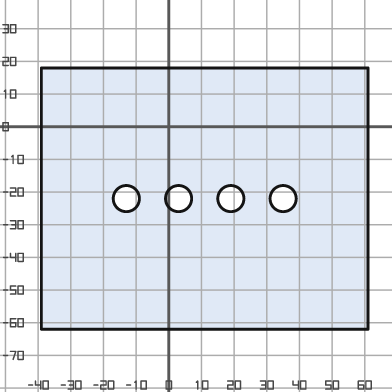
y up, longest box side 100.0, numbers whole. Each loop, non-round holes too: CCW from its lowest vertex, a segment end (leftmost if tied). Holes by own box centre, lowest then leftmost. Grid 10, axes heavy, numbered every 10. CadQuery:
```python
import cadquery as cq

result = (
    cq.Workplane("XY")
    .moveTo(-39.0, -62.0)
    .lineTo(61.0, -62.0)
    .lineTo(61.0, 18.0)
    .lineTo(-39.0, 18.0)
    .close()
    .moveTo(-13.0, -22.0)
    .circle(4.0)
    .moveTo(3.0, -22.0)
    .circle(4.0)
    .moveTo(19.0, -22.0)
    .circle(4.0)
    .moveTo(35.0, -22.0)
    .circle(4.0)
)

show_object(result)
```